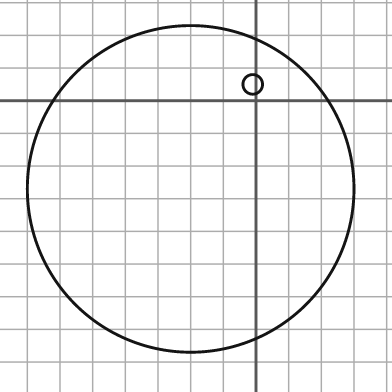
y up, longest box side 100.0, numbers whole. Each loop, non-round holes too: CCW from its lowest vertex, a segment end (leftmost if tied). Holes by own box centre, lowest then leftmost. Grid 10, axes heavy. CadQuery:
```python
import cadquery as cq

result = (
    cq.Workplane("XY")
    .moveTo(-20.0, -27.0)
    .circle(50.0)
    .moveTo(-1.0, 5.0)
    .circle(3.0)
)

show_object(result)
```